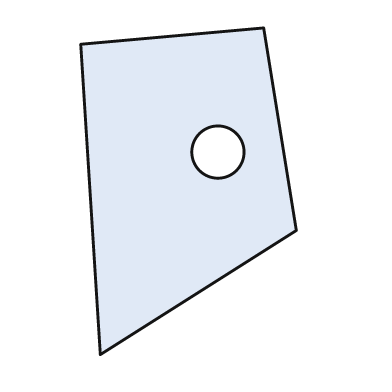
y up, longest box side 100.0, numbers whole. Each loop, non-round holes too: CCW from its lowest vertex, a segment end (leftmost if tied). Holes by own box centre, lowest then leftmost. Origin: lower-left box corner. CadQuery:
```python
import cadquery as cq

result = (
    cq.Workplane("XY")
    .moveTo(6.0, 0.0)
    .lineTo(66.0, 38.0)
    .lineTo(56.0, 100.0)
    .lineTo(0.0, 95.0)
    .close()
    .moveTo(42.0, 62.0)
    .circle(8.0)
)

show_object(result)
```